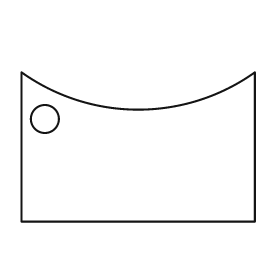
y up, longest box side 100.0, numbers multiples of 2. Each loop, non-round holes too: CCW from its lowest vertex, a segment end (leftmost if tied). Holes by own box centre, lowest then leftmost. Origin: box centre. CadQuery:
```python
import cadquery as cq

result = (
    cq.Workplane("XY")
    .moveTo(-50.0, -32.0)
    .lineTo(50.0, -32.0)
    .lineTo(50.0, 32.0)
    .threePointArc((0.0, 16.0), (-50.0, 32.0))
    .close()
    .moveTo(-40.0, 12.0)
    .circle(6.0)
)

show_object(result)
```